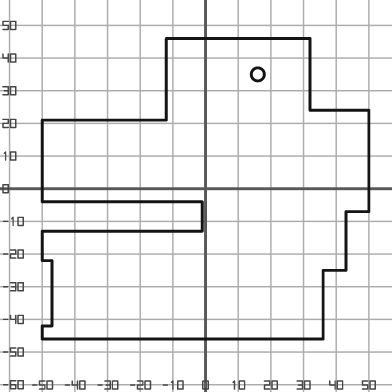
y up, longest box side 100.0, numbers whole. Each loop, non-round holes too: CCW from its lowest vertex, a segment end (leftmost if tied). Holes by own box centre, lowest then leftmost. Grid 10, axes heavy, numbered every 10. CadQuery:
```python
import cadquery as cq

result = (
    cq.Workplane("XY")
    .moveTo(-50.0, -46.0)
    .lineTo(36.0, -46.0)
    .lineTo(36.0, -25.0)
    .lineTo(43.0, -25.0)
    .lineTo(43.0, -7.0)
    .lineTo(50.0, -7.0)
    .lineTo(50.0, 24.0)
    .lineTo(32.0, 24.0)
    .lineTo(32.0, 46.0)
    .lineTo(-12.0, 46.0)
    .lineTo(-12.0, 21.0)
    .lineTo(-50.0, 21.0)
    .lineTo(-50.0, -4.0)
    .lineTo(-1.0, -4.0)
    .lineTo(-1.0, -13.0)
    .lineTo(-50.0, -13.0)
    .lineTo(-50.0, -22.0)
    .lineTo(-47.0, -22.0)
    .lineTo(-47.0, -42.0)
    .lineTo(-50.0, -42.0)
    .close()
    .moveTo(16.0, 35.0)
    .circle(2.0)
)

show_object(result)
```